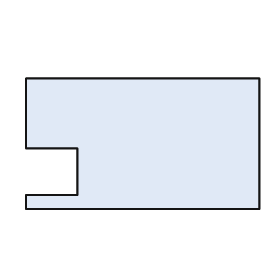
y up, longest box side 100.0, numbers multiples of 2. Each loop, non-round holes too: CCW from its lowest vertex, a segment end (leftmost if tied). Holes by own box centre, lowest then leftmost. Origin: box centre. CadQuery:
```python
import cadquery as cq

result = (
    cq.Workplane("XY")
    .moveTo(-50.0, -28.0)
    .lineTo(50.0, -28.0)
    .lineTo(50.0, 28.0)
    .lineTo(-50.0, 28.0)
    .lineTo(-50.0, -2.0)
    .lineTo(-28.0, -2.0)
    .lineTo(-28.0, -22.0)
    .lineTo(-50.0, -22.0)
    .close()
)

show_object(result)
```